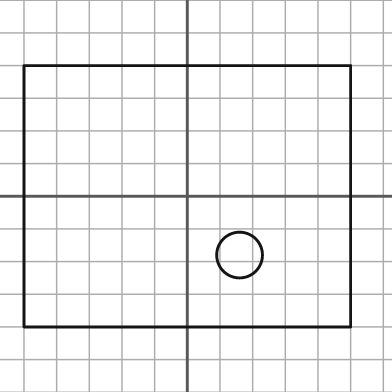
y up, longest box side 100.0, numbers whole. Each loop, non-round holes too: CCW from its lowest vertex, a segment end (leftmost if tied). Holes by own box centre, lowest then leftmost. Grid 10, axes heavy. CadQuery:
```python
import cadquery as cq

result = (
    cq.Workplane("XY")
    .moveTo(-50.0, -40.0)
    .lineTo(50.0, -40.0)
    .lineTo(50.0, 40.0)
    .lineTo(-50.0, 40.0)
    .close()
    .moveTo(16.0, -18.0)
    .circle(7.0)
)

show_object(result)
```